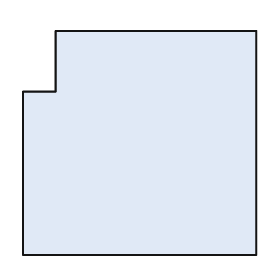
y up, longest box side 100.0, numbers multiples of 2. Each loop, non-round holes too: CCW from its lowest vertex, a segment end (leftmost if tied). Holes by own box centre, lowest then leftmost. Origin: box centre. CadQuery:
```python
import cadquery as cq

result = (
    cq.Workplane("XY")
    .moveTo(-50.0, -48.0)
    .lineTo(50.0, -48.0)
    .lineTo(50.0, 48.0)
    .lineTo(-36.0, 48.0)
    .lineTo(-36.0, 22.0)
    .lineTo(-50.0, 22.0)
    .close()
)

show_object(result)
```